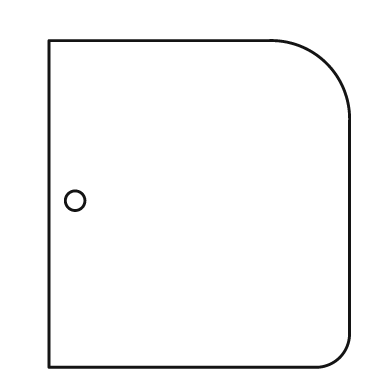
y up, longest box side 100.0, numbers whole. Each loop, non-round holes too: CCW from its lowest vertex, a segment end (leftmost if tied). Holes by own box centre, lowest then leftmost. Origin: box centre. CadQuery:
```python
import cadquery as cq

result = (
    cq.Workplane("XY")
    .moveTo(-46.0, -50.0)
    .lineTo(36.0, -50.0)
    .threePointArc((43.0, -47.0), (46.0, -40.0))
    .lineTo(46.0, 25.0)
    .threePointArc((39.0, 43.0), (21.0, 50.0))
    .lineTo(-46.0, 50.0)
    .close()
    .moveTo(-38.0, 1.0)
    .circle(3.0)
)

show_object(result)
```